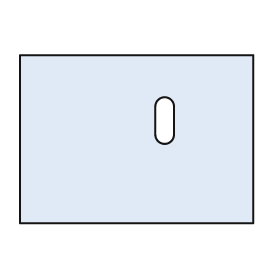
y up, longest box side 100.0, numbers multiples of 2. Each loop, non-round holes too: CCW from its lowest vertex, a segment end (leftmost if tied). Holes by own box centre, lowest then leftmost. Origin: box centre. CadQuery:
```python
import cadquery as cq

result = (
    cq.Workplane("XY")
    .moveTo(-50.0, -36.0)
    .lineTo(50.0, -36.0)
    .lineTo(50.0, 36.0)
    .lineTo(-50.0, 36.0)
    .close()
    .moveTo(8.0, 2.0)
    .threePointArc((12.0, -2.0), (16.0, 2.0))
    .lineTo(16.0, 14.0)
    .threePointArc((12.0, 18.0), (8.0, 14.0))
    .close()
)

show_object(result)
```